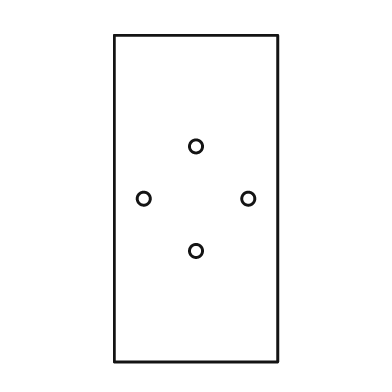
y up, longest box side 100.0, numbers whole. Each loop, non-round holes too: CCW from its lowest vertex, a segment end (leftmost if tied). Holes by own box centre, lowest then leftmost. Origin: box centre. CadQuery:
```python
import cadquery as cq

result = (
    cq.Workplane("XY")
    .moveTo(-25.0, -50.0)
    .lineTo(25.0, -50.0)
    .lineTo(25.0, 50.0)
    .lineTo(-25.0, 50.0)
    .close()
    .moveTo(0.0, -16.0)
    .circle(2.0)
    .moveTo(-16.0, 0.0)
    .circle(2.0)
    .moveTo(16.0, 0.0)
    .circle(2.0)
    .moveTo(0.0, 16.0)
    .circle(2.0)
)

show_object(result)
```